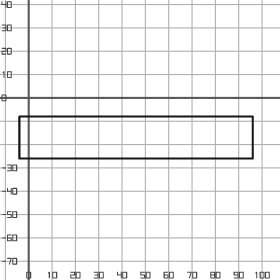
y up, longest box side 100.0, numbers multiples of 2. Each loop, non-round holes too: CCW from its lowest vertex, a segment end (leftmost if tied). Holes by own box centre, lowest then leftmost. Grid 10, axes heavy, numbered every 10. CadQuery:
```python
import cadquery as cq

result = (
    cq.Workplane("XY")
    .moveTo(-4.0, -26.0)
    .lineTo(96.0, -26.0)
    .lineTo(96.0, -8.0)
    .lineTo(-4.0, -8.0)
    .close()
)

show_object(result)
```